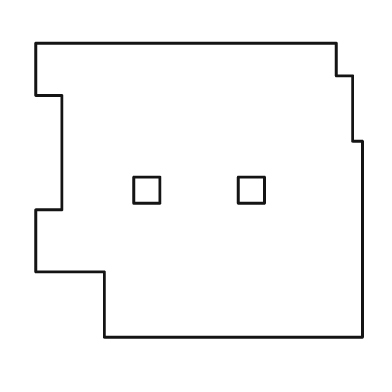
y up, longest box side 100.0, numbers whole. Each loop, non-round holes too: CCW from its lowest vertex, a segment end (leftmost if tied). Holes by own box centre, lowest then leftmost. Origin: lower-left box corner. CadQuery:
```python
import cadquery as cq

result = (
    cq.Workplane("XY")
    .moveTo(21.0, 0.0)
    .lineTo(100.0, 0.0)
    .lineTo(100.0, 60.0)
    .lineTo(97.0, 60.0)
    .lineTo(97.0, 80.0)
    .lineTo(92.0, 80.0)
    .lineTo(92.0, 90.0)
    .lineTo(0.0, 90.0)
    .lineTo(0.0, 74.0)
    .lineTo(8.0, 74.0)
    .lineTo(8.0, 39.0)
    .lineTo(0.0, 39.0)
    .lineTo(0.0, 20.0)
    .lineTo(21.0, 20.0)
    .close()
    .moveTo(30.0, 41.0)
    .lineTo(38.0, 41.0)
    .lineTo(38.0, 49.0)
    .lineTo(30.0, 49.0)
    .close()
    .moveTo(62.0, 41.0)
    .lineTo(70.0, 41.0)
    .lineTo(70.0, 49.0)
    .lineTo(62.0, 49.0)
    .close()
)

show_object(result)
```